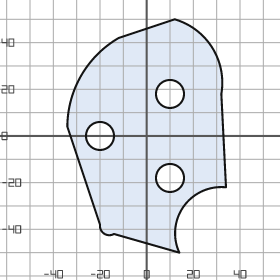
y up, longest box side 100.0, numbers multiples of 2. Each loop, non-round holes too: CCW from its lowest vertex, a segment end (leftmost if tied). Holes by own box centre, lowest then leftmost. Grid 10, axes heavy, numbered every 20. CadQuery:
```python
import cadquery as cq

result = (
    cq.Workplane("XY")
    .moveTo(14.0, -50.0)
    .threePointArc((16.0, -30.0), (34.0, -22.0))
    .lineTo(32.0, 18.0)
    .threePointArc((28.0, 38.0), (12.0, 50.0))
    .lineTo(-12.0, 42.0)
    .threePointArc((-28.0, 26.0), (-34.0, 4.0))
    .lineTo(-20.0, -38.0)
    .threePointArc((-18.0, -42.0), (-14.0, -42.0))
    .close()
    .moveTo(10.0, -18.0)
    .circle(6.0)
    .moveTo(-20.0, 0.0)
    .circle(6.0)
    .moveTo(10.0, 18.0)
    .circle(6.0)
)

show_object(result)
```